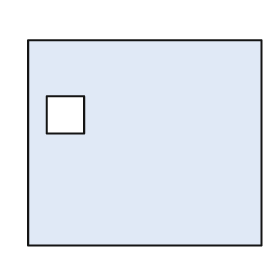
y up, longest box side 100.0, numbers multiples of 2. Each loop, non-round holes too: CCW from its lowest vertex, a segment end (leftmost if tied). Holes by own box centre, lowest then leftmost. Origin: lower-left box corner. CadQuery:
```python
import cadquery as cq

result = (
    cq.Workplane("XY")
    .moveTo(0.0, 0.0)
    .lineTo(100.0, 0.0)
    .lineTo(100.0, 88.0)
    .lineTo(0.0, 88.0)
    .close()
    .moveTo(8.0, 48.0)
    .lineTo(24.0, 48.0)
    .lineTo(24.0, 64.0)
    .lineTo(8.0, 64.0)
    .close()
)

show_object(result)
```